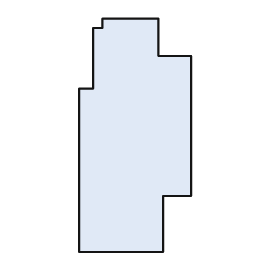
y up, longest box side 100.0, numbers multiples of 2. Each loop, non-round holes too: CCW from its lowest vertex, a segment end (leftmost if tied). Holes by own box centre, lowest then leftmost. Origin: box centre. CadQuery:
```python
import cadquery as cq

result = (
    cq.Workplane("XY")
    .moveTo(-24.0, -50.0)
    .lineTo(12.0, -50.0)
    .lineTo(12.0, -26.0)
    .lineTo(24.0, -26.0)
    .lineTo(24.0, 34.0)
    .lineTo(10.0, 34.0)
    .lineTo(10.0, 50.0)
    .lineTo(-14.0, 50.0)
    .lineTo(-14.0, 46.0)
    .lineTo(-18.0, 46.0)
    .lineTo(-18.0, 20.0)
    .lineTo(-24.0, 20.0)
    .close()
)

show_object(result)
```